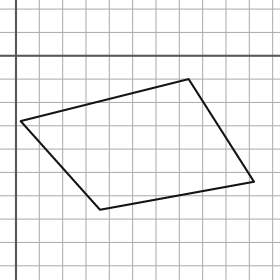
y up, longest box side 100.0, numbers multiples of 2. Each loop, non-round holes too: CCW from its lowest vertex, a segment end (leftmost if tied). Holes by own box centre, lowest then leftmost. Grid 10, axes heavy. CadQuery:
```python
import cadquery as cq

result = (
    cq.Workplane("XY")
    .moveTo(36.0, -66.0)
    .lineTo(102.0, -54.0)
    .lineTo(74.0, -10.0)
    .lineTo(2.0, -28.0)
    .close()
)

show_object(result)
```